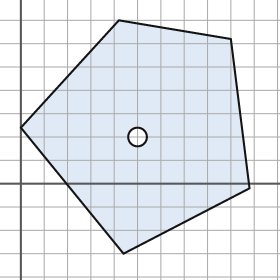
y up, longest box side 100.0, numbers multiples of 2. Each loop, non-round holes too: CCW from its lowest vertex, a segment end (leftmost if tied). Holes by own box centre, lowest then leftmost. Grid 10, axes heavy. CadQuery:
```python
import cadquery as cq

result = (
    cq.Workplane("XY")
    .moveTo(44.0, -30.0)
    .lineTo(98.0, -2.0)
    .lineTo(90.0, 62.0)
    .lineTo(42.0, 70.0)
    .lineTo(0.0, 24.0)
    .close()
    .moveTo(50.0, 20.0)
    .circle(4.0)
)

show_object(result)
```